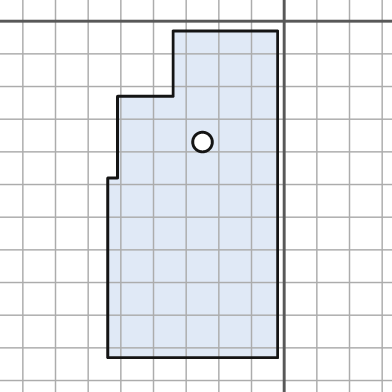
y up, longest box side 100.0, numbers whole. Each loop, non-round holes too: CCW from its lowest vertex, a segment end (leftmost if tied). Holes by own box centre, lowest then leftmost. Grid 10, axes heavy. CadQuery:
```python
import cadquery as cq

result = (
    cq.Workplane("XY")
    .moveTo(-54.0, -103.0)
    .lineTo(-2.0, -103.0)
    .lineTo(-2.0, -3.0)
    .lineTo(-34.0, -3.0)
    .lineTo(-34.0, -23.0)
    .lineTo(-51.0, -23.0)
    .lineTo(-51.0, -48.0)
    .lineTo(-54.0, -48.0)
    .close()
    .moveTo(-25.0, -37.0)
    .circle(3.0)
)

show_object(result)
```